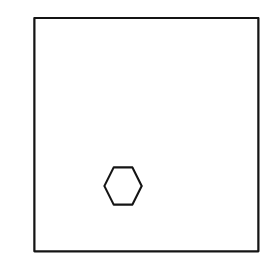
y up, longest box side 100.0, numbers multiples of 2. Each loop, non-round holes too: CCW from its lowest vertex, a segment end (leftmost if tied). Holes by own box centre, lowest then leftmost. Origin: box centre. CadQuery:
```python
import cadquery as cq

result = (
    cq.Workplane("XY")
    .moveTo(-48.0, -50.0)
    .lineTo(48.0, -50.0)
    .lineTo(48.0, 50.0)
    .lineTo(-48.0, 50.0)
    .close()
    .moveTo(-14.0, -30.0)
    .lineTo(-6.0, -30.0)
    .lineTo(-2.0, -22.0)
    .lineTo(-6.0, -14.0)
    .lineTo(-14.0, -14.0)
    .lineTo(-18.0, -22.0)
    .close()
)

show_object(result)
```